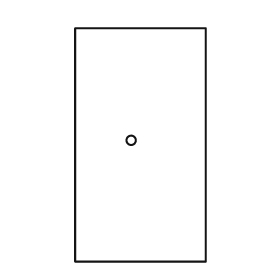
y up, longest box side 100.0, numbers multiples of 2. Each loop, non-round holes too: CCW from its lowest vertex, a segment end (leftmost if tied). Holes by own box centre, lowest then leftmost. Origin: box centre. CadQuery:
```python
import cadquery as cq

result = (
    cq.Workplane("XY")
    .moveTo(-28.0, -50.0)
    .lineTo(28.0, -50.0)
    .lineTo(28.0, 50.0)
    .lineTo(-28.0, 50.0)
    .close()
    .moveTo(-4.0, 2.0)
    .circle(2.0)
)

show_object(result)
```